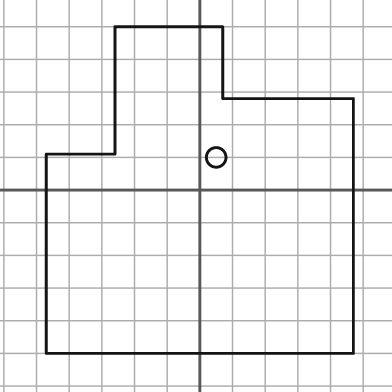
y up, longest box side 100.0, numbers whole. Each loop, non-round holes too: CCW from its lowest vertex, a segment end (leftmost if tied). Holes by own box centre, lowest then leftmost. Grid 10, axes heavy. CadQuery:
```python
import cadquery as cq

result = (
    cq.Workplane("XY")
    .moveTo(-47.0, -50.0)
    .lineTo(47.0, -50.0)
    .lineTo(47.0, 28.0)
    .lineTo(7.0, 28.0)
    .lineTo(7.0, 50.0)
    .lineTo(-26.0, 50.0)
    .lineTo(-26.0, 11.0)
    .lineTo(-47.0, 11.0)
    .close()
    .moveTo(5.0, 10.0)
    .circle(3.0)
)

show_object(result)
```